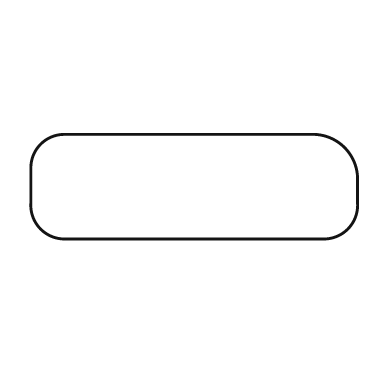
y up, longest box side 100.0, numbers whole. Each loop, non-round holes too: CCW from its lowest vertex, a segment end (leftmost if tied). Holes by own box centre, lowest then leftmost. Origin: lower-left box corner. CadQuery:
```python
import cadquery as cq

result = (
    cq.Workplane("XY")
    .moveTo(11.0, 0.0)
    .lineTo(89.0, 0.0)
    .threePointArc((97.0, 3.0), (100.0, 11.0))
    .lineTo(100.0, 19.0)
    .threePointArc((96.0, 28.0), (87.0, 32.0))
    .lineTo(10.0, 32.0)
    .threePointArc((3.0, 29.0), (0.0, 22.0))
    .lineTo(0.0, 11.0)
    .threePointArc((3.0, 3.0), (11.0, 0.0))
    .close()
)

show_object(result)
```